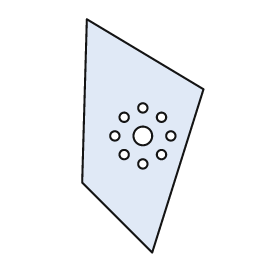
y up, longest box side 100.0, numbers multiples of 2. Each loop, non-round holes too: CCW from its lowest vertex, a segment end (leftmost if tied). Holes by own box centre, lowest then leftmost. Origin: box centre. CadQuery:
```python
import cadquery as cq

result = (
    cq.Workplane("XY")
    .moveTo(4.0, -50.0)
    .lineTo(26.0, 20.0)
    .lineTo(-24.0, 50.0)
    .lineTo(-26.0, -20.0)
    .close()
    .moveTo(0.0, -12.0)
    .circle(2.0)
    .moveTo(-8.0, -8.0)
    .circle(2.0)
    .moveTo(8.0, -8.0)
    .circle(2.0)
    .moveTo(-12.0, 0.0)
    .circle(2.0)
    .moveTo(0.0, 0.0)
    .circle(4.0)
    .moveTo(12.0, 0.0)
    .circle(2.0)
    .moveTo(-8.0, 8.0)
    .circle(2.0)
    .moveTo(8.0, 8.0)
    .circle(2.0)
    .moveTo(0.0, 12.0)
    .circle(2.0)
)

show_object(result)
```